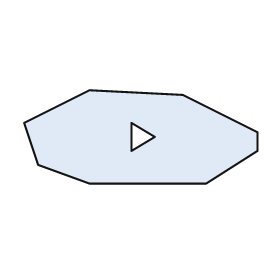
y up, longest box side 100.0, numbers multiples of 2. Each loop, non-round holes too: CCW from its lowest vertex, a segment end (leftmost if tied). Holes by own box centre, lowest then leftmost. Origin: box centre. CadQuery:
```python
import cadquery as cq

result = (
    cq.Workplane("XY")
    .moveTo(-22.0, -20.0)
    .lineTo(28.0, -20.0)
    .lineTo(50.0, -6.0)
    .lineTo(50.0, 2.0)
    .lineTo(18.0, 18.0)
    .lineTo(-22.0, 20.0)
    .lineTo(-50.0, 6.0)
    .lineTo(-44.0, -12.0)
    .close()
    .moveTo(-4.0, -6.0)
    .lineTo(6.0, 0.0)
    .lineTo(-4.0, 6.0)
    .close()
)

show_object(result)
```